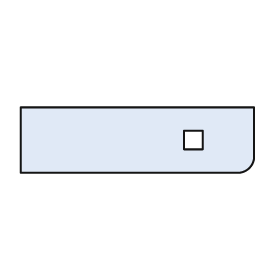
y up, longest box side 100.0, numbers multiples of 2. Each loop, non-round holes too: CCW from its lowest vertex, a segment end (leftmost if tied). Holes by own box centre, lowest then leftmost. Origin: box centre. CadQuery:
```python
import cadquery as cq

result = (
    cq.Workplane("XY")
    .moveTo(-50.0, -14.0)
    .lineTo(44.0, -14.0)
    .threePointArc((48.0, -12.0), (50.0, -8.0))
    .lineTo(50.0, 14.0)
    .lineTo(-50.0, 14.0)
    .close()
    .moveTo(20.0, -4.0)
    .lineTo(28.0, -4.0)
    .lineTo(28.0, 4.0)
    .lineTo(20.0, 4.0)
    .close()
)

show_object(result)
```